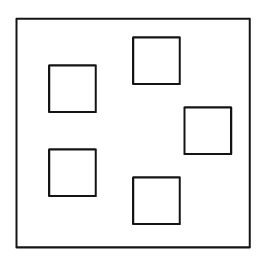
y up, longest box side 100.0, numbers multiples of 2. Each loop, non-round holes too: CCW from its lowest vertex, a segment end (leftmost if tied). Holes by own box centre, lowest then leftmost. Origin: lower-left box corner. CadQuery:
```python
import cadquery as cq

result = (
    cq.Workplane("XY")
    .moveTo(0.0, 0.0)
    .lineTo(100.0, 0.0)
    .lineTo(100.0, 98.0)
    .lineTo(0.0, 98.0)
    .close()
    .moveTo(50.0, 10.0)
    .lineTo(70.0, 10.0)
    .lineTo(70.0, 30.0)
    .lineTo(50.0, 30.0)
    .close()
    .moveTo(14.0, 22.0)
    .lineTo(34.0, 22.0)
    .lineTo(34.0, 42.0)
    .lineTo(14.0, 42.0)
    .close()
    .moveTo(72.0, 40.0)
    .lineTo(92.0, 40.0)
    .lineTo(92.0, 60.0)
    .lineTo(72.0, 60.0)
    .close()
    .moveTo(14.0, 58.0)
    .lineTo(34.0, 58.0)
    .lineTo(34.0, 78.0)
    .lineTo(14.0, 78.0)
    .close()
    .moveTo(50.0, 70.0)
    .lineTo(70.0, 70.0)
    .lineTo(70.0, 90.0)
    .lineTo(50.0, 90.0)
    .close()
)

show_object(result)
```